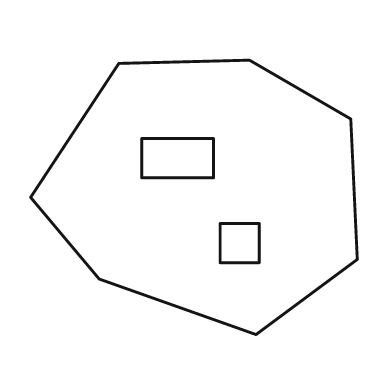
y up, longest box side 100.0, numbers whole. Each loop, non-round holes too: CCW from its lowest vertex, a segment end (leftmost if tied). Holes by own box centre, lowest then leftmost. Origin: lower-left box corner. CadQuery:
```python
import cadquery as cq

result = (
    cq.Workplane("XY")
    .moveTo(69.0, 0.0)
    .lineTo(100.0, 23.0)
    .lineTo(98.0, 66.0)
    .lineTo(67.0, 84.0)
    .lineTo(27.0, 83.0)
    .lineTo(0.0, 42.0)
    .lineTo(21.0, 17.0)
    .close()
    .moveTo(58.0, 22.0)
    .lineTo(70.0, 22.0)
    .lineTo(70.0, 34.0)
    .lineTo(58.0, 34.0)
    .close()
    .moveTo(34.0, 48.0)
    .lineTo(56.0, 48.0)
    .lineTo(56.0, 60.0)
    .lineTo(34.0, 60.0)
    .close()
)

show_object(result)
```